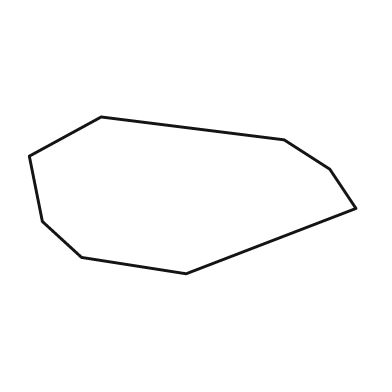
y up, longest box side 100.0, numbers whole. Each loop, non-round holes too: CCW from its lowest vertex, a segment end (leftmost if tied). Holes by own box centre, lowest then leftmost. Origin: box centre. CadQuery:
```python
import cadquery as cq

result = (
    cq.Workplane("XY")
    .moveTo(-2.0, -24.0)
    .lineTo(50.0, -4.0)
    .lineTo(42.0, 8.0)
    .lineTo(28.0, 17.0)
    .lineTo(-28.0, 24.0)
    .lineTo(-50.0, 12.0)
    .lineTo(-46.0, -8.0)
    .lineTo(-34.0, -19.0)
    .close()
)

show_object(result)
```